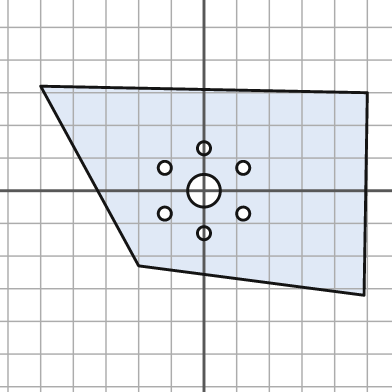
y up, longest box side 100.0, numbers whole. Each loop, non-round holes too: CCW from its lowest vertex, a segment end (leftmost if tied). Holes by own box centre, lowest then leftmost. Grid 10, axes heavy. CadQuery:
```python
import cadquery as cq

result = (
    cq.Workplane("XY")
    .moveTo(49.0, -32.0)
    .lineTo(50.0, 30.0)
    .lineTo(-50.0, 32.0)
    .lineTo(-20.0, -23.0)
    .close()
    .moveTo(0.0, -13.0)
    .circle(2.0)
    .moveTo(-12.0, -7.0)
    .circle(2.0)
    .moveTo(12.0, -7.0)
    .circle(2.0)
    .moveTo(0.0, 0.0)
    .circle(5.0)
    .moveTo(-12.0, 7.0)
    .circle(2.0)
    .moveTo(12.0, 7.0)
    .circle(2.0)
    .moveTo(0.0, 13.0)
    .circle(2.0)
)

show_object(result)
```